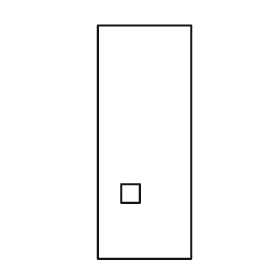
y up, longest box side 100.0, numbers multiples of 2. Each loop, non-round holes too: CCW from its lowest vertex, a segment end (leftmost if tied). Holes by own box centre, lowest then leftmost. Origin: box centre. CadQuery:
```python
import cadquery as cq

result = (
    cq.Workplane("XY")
    .moveTo(-20.0, -50.0)
    .lineTo(20.0, -50.0)
    .lineTo(20.0, 50.0)
    .lineTo(-20.0, 50.0)
    .close()
    .moveTo(-10.0, -26.0)
    .lineTo(-2.0, -26.0)
    .lineTo(-2.0, -18.0)
    .lineTo(-10.0, -18.0)
    .close()
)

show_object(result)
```